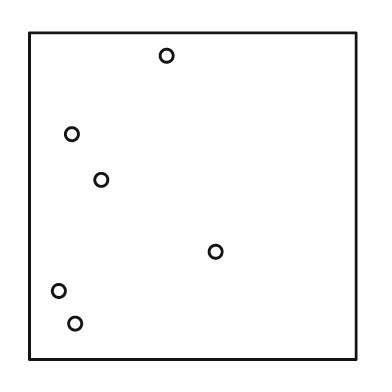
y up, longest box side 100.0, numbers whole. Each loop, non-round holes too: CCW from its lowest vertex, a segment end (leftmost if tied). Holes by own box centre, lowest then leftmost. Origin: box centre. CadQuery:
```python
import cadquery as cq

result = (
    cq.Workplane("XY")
    .moveTo(-50.0, -50.0)
    .lineTo(50.0, -50.0)
    .lineTo(50.0, 50.0)
    .lineTo(-50.0, 50.0)
    .close()
    .moveTo(-36.0, -39.0)
    .circle(2.0)
    .moveTo(-41.0, -29.0)
    .circle(2.0)
    .moveTo(7.0, -17.0)
    .circle(2.0)
    .moveTo(-28.0, 5.0)
    .circle(2.0)
    .moveTo(-37.0, 19.0)
    .circle(2.0)
    .moveTo(-8.0, 43.0)
    .circle(2.0)
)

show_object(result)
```